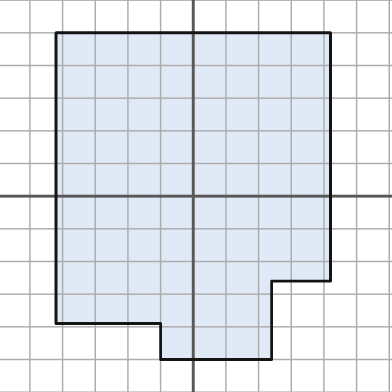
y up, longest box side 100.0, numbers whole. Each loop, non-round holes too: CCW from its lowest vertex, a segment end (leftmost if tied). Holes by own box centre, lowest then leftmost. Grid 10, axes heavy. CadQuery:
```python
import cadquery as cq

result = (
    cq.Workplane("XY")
    .moveTo(-10.0, -50.0)
    .lineTo(24.0, -50.0)
    .lineTo(24.0, -26.0)
    .lineTo(42.0, -26.0)
    .lineTo(42.0, 50.0)
    .lineTo(-42.0, 50.0)
    .lineTo(-42.0, -39.0)
    .lineTo(-10.0, -39.0)
    .close()
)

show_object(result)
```